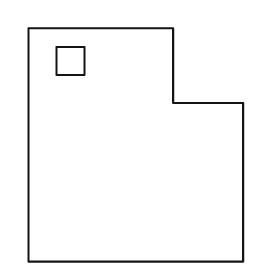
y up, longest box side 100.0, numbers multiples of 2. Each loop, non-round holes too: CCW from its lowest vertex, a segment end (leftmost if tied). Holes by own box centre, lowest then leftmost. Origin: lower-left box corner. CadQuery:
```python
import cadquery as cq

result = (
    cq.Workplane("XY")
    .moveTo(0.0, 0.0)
    .lineTo(92.0, 0.0)
    .lineTo(92.0, 68.0)
    .lineTo(62.0, 68.0)
    .lineTo(62.0, 100.0)
    .lineTo(0.0, 100.0)
    .close()
    .moveTo(12.0, 80.0)
    .lineTo(24.0, 80.0)
    .lineTo(24.0, 92.0)
    .lineTo(12.0, 92.0)
    .close()
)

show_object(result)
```